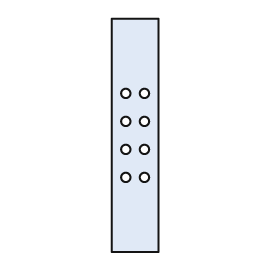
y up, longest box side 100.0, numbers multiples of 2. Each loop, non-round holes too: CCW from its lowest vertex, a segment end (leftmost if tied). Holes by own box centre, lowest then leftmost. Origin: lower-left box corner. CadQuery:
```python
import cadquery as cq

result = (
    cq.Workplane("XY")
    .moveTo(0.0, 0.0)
    .lineTo(20.0, 0.0)
    .lineTo(20.0, 100.0)
    .lineTo(0.0, 100.0)
    .close()
    .moveTo(6.0, 32.0)
    .circle(2.0)
    .moveTo(14.0, 32.0)
    .circle(2.0)
    .moveTo(6.0, 44.0)
    .circle(2.0)
    .moveTo(14.0, 44.0)
    .circle(2.0)
    .moveTo(6.0, 56.0)
    .circle(2.0)
    .moveTo(14.0, 56.0)
    .circle(2.0)
    .moveTo(6.0, 68.0)
    .circle(2.0)
    .moveTo(14.0, 68.0)
    .circle(2.0)
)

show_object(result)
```